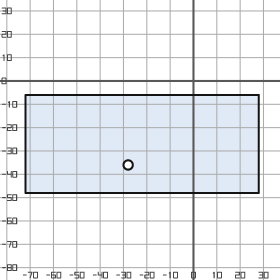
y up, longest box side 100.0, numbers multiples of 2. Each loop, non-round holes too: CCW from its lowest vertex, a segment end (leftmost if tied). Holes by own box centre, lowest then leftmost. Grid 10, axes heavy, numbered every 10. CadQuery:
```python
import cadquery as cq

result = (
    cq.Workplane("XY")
    .moveTo(-72.0, -48.0)
    .lineTo(28.0, -48.0)
    .lineTo(28.0, -6.0)
    .lineTo(-72.0, -6.0)
    .close()
    .moveTo(-28.0, -36.0)
    .circle(2.0)
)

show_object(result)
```